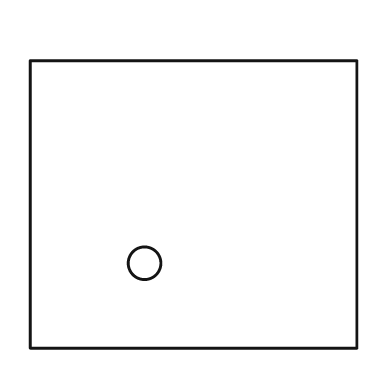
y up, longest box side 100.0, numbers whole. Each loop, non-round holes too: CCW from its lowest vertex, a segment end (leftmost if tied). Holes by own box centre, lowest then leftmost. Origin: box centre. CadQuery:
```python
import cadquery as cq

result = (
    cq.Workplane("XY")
    .moveTo(-50.0, -44.0)
    .lineTo(50.0, -44.0)
    .lineTo(50.0, 44.0)
    .lineTo(-50.0, 44.0)
    .close()
    .moveTo(-15.0, -18.0)
    .circle(5.0)
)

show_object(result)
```